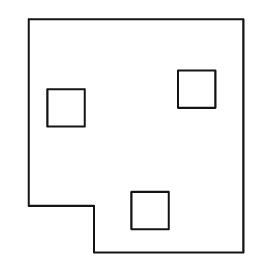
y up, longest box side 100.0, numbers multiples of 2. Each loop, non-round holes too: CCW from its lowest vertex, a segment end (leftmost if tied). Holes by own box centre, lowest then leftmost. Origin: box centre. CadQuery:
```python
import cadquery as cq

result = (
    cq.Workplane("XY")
    .moveTo(-18.0, -50.0)
    .lineTo(46.0, -50.0)
    .lineTo(46.0, 50.0)
    .lineTo(-46.0, 50.0)
    .lineTo(-46.0, -30.0)
    .lineTo(-18.0, -30.0)
    .close()
    .moveTo(-2.0, -40.0)
    .lineTo(14.0, -40.0)
    .lineTo(14.0, -24.0)
    .lineTo(-2.0, -24.0)
    .close()
    .moveTo(-38.0, 4.0)
    .lineTo(-22.0, 4.0)
    .lineTo(-22.0, 20.0)
    .lineTo(-38.0, 20.0)
    .close()
    .moveTo(18.0, 12.0)
    .lineTo(34.0, 12.0)
    .lineTo(34.0, 28.0)
    .lineTo(18.0, 28.0)
    .close()
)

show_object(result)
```